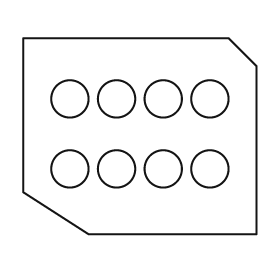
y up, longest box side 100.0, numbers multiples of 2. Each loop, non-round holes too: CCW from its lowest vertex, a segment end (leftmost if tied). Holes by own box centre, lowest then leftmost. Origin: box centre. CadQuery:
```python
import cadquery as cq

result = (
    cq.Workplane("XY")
    .moveTo(-22.0, -42.0)
    .lineTo(50.0, -42.0)
    .lineTo(50.0, 30.0)
    .lineTo(38.0, 42.0)
    .lineTo(-50.0, 42.0)
    .lineTo(-50.0, -24.0)
    .close()
    .moveTo(-30.0, -14.0)
    .circle(8.0)
    .moveTo(-10.0, -14.0)
    .circle(8.0)
    .moveTo(10.0, -14.0)
    .circle(8.0)
    .moveTo(30.0, -14.0)
    .circle(8.0)
    .moveTo(-30.0, 16.0)
    .circle(8.0)
    .moveTo(-10.0, 16.0)
    .circle(8.0)
    .moveTo(10.0, 16.0)
    .circle(8.0)
    .moveTo(30.0, 16.0)
    .circle(8.0)
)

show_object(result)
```